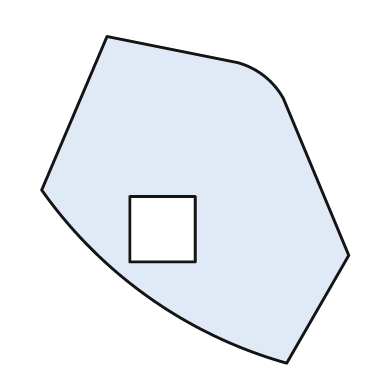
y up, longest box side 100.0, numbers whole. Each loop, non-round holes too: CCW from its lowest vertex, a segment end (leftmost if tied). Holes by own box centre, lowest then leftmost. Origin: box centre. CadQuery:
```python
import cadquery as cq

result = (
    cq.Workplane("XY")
    .moveTo(28.0, -50.0)
    .lineTo(47.0, -17.0)
    .lineTo(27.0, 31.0)
    .threePointArc((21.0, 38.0), (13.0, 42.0))
    .lineTo(-27.0, 50.0)
    .lineTo(-47.0, 3.0)
    .threePointArc((-14.0, -30.0), (28.0, -50.0))
    .close()
    .moveTo(-20.0, -19.0)
    .lineTo(0.0, -19.0)
    .lineTo(0.0, 1.0)
    .lineTo(-20.0, 1.0)
    .close()
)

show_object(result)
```